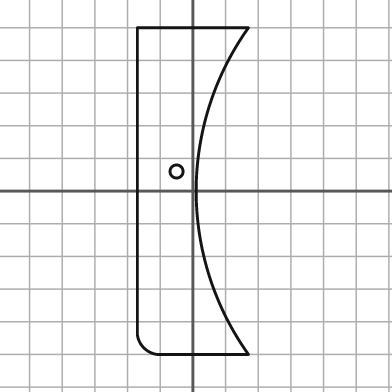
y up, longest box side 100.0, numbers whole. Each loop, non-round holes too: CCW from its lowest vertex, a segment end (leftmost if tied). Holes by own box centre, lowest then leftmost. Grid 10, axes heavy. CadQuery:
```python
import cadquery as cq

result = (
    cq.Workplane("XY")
    .moveTo(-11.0, -50.0)
    .lineTo(17.0, -50.0)
    .threePointArc((1.0, 0.0), (17.0, 50.0))
    .lineTo(-17.0, 50.0)
    .lineTo(-17.0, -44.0)
    .threePointArc((-15.0, -48.0), (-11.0, -50.0))
    .close()
    .moveTo(-5.0, 6.0)
    .circle(2.0)
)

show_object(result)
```